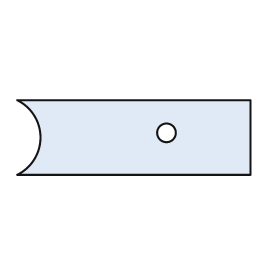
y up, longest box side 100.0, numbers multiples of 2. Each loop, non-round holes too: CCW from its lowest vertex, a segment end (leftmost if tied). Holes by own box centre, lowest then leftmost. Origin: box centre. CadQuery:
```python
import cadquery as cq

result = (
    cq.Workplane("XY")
    .moveTo(-50.0, -16.0)
    .lineTo(50.0, -16.0)
    .lineTo(50.0, 16.0)
    .lineTo(-50.0, 16.0)
    .threePointArc((-40.0, 0.0), (-50.0, -16.0))
    .close()
    .moveTo(14.0, 2.0)
    .circle(4.0)
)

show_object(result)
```